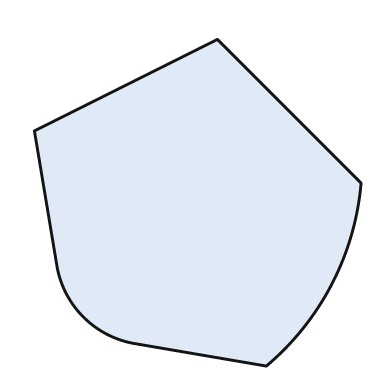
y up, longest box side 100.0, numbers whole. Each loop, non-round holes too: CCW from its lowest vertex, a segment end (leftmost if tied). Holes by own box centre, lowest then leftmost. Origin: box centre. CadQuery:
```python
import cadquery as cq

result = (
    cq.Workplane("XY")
    .moveTo(21.0, -50.0)
    .threePointArc((41.0, -25.0), (50.0, 6.0))
    .lineTo(6.0, 50.0)
    .lineTo(-50.0, 22.0)
    .lineTo(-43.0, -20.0)
    .threePointArc((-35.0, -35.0), (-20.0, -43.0))
    .close()
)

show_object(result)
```